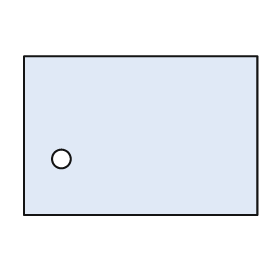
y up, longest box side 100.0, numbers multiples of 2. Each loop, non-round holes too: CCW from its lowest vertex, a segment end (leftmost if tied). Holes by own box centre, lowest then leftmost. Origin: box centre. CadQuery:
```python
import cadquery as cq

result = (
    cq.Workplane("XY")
    .moveTo(-50.0, -34.0)
    .lineTo(50.0, -34.0)
    .lineTo(50.0, 34.0)
    .lineTo(-50.0, 34.0)
    .close()
    .moveTo(-34.0, -10.0)
    .circle(4.0)
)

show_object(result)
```